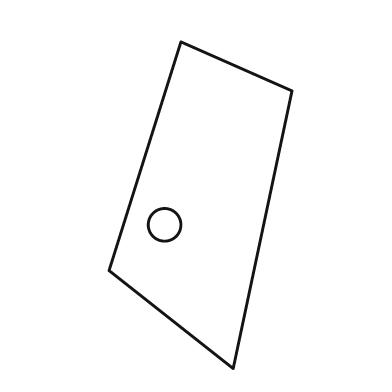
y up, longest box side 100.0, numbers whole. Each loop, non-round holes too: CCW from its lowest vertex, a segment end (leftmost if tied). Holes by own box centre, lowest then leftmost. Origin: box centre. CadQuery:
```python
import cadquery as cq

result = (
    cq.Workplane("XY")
    .moveTo(10.0, -50.0)
    .lineTo(28.0, 35.0)
    .lineTo(-6.0, 50.0)
    .lineTo(-28.0, -20.0)
    .close()
    .moveTo(-11.0, -6.0)
    .circle(5.0)
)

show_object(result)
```